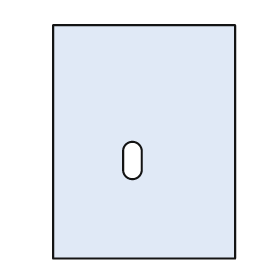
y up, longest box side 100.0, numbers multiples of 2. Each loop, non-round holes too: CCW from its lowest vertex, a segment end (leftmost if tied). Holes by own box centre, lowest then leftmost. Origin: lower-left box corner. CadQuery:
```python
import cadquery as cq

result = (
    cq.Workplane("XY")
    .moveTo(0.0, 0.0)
    .lineTo(78.0, 0.0)
    .lineTo(78.0, 100.0)
    .lineTo(0.0, 100.0)
    .close()
    .moveTo(30.0, 38.0)
    .threePointArc((34.0, 34.0), (38.0, 38.0))
    .lineTo(38.0, 46.0)
    .threePointArc((34.0, 50.0), (30.0, 46.0))
    .close()
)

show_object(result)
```